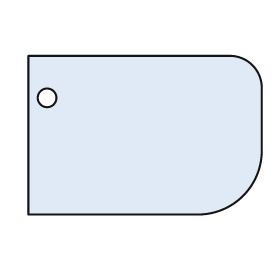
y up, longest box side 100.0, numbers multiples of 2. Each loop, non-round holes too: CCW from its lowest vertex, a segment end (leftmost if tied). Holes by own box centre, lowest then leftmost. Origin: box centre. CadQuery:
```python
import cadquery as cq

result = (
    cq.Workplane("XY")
    .moveTo(-50.0, -34.0)
    .lineTo(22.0, -34.0)
    .threePointArc((42.0, -26.0), (50.0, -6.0))
    .lineTo(50.0, 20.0)
    .threePointArc((46.0, 30.0), (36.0, 34.0))
    .lineTo(-50.0, 34.0)
    .close()
    .moveTo(-42.0, 16.0)
    .circle(4.0)
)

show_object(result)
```